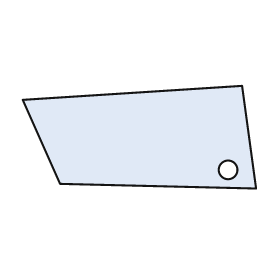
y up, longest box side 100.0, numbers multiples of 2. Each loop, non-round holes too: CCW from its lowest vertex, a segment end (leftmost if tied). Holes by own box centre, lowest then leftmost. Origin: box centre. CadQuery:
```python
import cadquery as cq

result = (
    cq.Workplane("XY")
    .moveTo(50.0, -22.0)
    .lineTo(44.0, 22.0)
    .lineTo(-50.0, 16.0)
    .lineTo(-34.0, -20.0)
    .close()
    .moveTo(38.0, -14.0)
    .circle(4.0)
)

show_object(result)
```